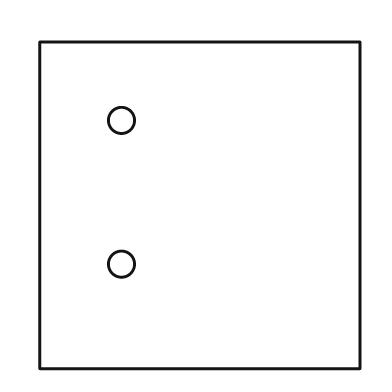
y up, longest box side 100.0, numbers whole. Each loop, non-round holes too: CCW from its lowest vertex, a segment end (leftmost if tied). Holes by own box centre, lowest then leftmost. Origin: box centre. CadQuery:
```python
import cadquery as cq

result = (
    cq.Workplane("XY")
    .moveTo(-49.0, -50.0)
    .lineTo(49.0, -50.0)
    .lineTo(49.0, 50.0)
    .lineTo(-49.0, 50.0)
    .close()
    .moveTo(-24.0, -18.0)
    .circle(4.0)
    .moveTo(-24.0, 26.0)
    .circle(4.0)
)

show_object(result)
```